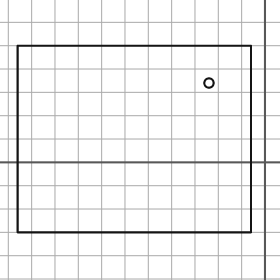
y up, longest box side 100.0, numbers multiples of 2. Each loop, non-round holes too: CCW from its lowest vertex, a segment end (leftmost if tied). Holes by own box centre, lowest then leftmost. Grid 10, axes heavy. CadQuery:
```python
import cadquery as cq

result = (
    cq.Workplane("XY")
    .moveTo(-106.0, -30.0)
    .lineTo(-6.0, -30.0)
    .lineTo(-6.0, 50.0)
    .lineTo(-106.0, 50.0)
    .close()
    .moveTo(-24.0, 34.0)
    .circle(2.0)
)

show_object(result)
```